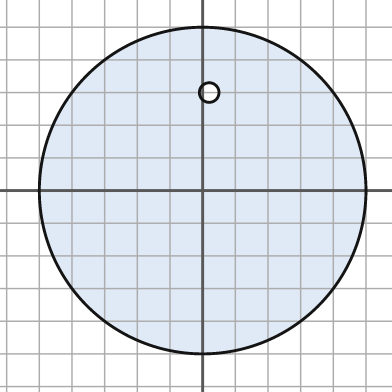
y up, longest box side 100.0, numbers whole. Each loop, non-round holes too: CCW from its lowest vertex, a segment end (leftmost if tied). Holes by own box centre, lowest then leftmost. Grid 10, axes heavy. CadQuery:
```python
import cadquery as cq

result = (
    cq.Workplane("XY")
    .moveTo(0.0, 0.0)
    .circle(50.0)
    .moveTo(2.0, 30.0)
    .circle(3.0)
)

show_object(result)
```